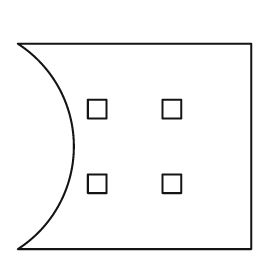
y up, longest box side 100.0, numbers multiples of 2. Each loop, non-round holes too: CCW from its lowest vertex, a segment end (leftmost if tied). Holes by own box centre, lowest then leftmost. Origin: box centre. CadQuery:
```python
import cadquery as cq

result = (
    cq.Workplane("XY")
    .moveTo(-50.0, -44.0)
    .lineTo(50.0, -44.0)
    .lineTo(50.0, 44.0)
    .lineTo(-50.0, 44.0)
    .threePointArc((-26.0, 0.0), (-50.0, -44.0))
    .close()
    .moveTo(-20.0, -20.0)
    .lineTo(-12.0, -20.0)
    .lineTo(-12.0, -12.0)
    .lineTo(-20.0, -12.0)
    .close()
    .moveTo(12.0, -20.0)
    .lineTo(20.0, -20.0)
    .lineTo(20.0, -12.0)
    .lineTo(12.0, -12.0)
    .close()
    .moveTo(-20.0, 12.0)
    .lineTo(-12.0, 12.0)
    .lineTo(-12.0, 20.0)
    .lineTo(-20.0, 20.0)
    .close()
    .moveTo(12.0, 12.0)
    .lineTo(20.0, 12.0)
    .lineTo(20.0, 20.0)
    .lineTo(12.0, 20.0)
    .close()
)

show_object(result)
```